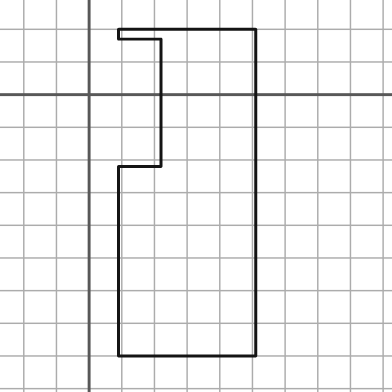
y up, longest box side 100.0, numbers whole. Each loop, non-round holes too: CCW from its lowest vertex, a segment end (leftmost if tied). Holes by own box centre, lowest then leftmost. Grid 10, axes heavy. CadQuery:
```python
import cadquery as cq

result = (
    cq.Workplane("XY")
    .moveTo(9.0, -80.0)
    .lineTo(51.0, -80.0)
    .lineTo(51.0, 20.0)
    .lineTo(9.0, 20.0)
    .lineTo(9.0, 17.0)
    .lineTo(22.0, 17.0)
    .lineTo(22.0, -22.0)
    .lineTo(9.0, -22.0)
    .close()
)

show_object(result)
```